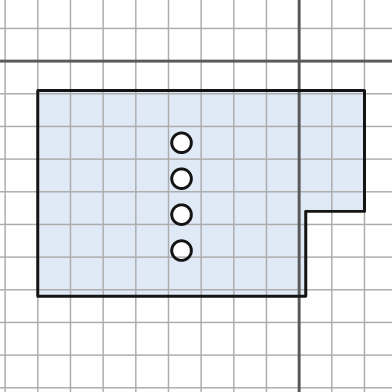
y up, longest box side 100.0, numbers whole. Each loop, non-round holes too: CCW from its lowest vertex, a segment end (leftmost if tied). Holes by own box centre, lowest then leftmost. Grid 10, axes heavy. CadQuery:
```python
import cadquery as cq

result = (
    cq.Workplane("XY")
    .moveTo(-80.0, -72.0)
    .lineTo(2.0, -72.0)
    .lineTo(2.0, -46.0)
    .lineTo(20.0, -46.0)
    .lineTo(20.0, -9.0)
    .lineTo(-80.0, -9.0)
    .close()
    .moveTo(-36.0, -58.0)
    .circle(3.0)
    .moveTo(-36.0, -47.0)
    .circle(3.0)
    .moveTo(-36.0, -36.0)
    .circle(3.0)
    .moveTo(-36.0, -25.0)
    .circle(3.0)
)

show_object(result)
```